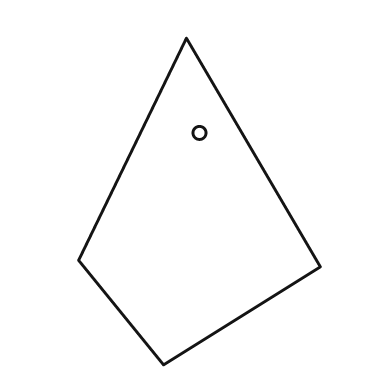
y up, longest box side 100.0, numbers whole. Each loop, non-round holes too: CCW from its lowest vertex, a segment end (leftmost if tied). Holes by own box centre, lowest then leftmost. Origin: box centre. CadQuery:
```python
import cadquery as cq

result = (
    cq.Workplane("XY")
    .moveTo(-11.0, -50.0)
    .lineTo(37.0, -20.0)
    .lineTo(-4.0, 50.0)
    .lineTo(-37.0, -18.0)
    .close()
    .moveTo(0.0, 21.0)
    .circle(2.0)
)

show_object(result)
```